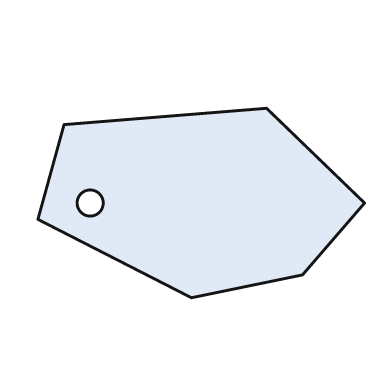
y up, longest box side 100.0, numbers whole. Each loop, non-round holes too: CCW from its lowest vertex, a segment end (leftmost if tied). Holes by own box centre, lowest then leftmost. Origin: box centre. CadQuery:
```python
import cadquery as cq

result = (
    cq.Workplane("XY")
    .moveTo(-3.0, -29.0)
    .lineTo(31.0, -22.0)
    .lineTo(50.0, 0.0)
    .lineTo(20.0, 29.0)
    .lineTo(-42.0, 24.0)
    .lineTo(-50.0, -5.0)
    .close()
    .moveTo(-34.0, 0.0)
    .circle(4.0)
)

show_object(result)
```